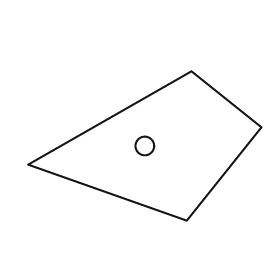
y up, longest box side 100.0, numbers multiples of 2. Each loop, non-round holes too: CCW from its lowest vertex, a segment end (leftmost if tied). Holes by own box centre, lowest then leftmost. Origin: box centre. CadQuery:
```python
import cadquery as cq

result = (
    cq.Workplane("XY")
    .moveTo(18.0, -32.0)
    .lineTo(50.0, 8.0)
    .lineTo(20.0, 32.0)
    .lineTo(-50.0, -8.0)
    .close()
    .moveTo(0.0, 0.0)
    .circle(4.0)
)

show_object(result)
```